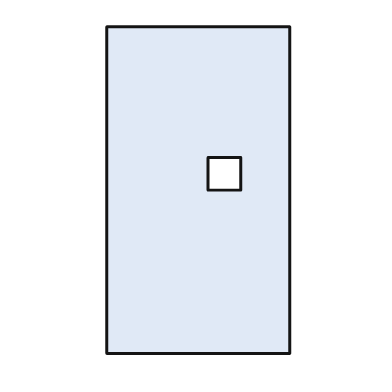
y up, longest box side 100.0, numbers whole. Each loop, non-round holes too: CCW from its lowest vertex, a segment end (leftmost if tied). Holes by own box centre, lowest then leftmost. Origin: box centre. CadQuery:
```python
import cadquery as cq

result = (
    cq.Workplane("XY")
    .moveTo(-28.0, -50.0)
    .lineTo(28.0, -50.0)
    .lineTo(28.0, 50.0)
    .lineTo(-28.0, 50.0)
    .close()
    .moveTo(3.0, 0.0)
    .lineTo(13.0, 0.0)
    .lineTo(13.0, 10.0)
    .lineTo(3.0, 10.0)
    .close()
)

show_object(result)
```